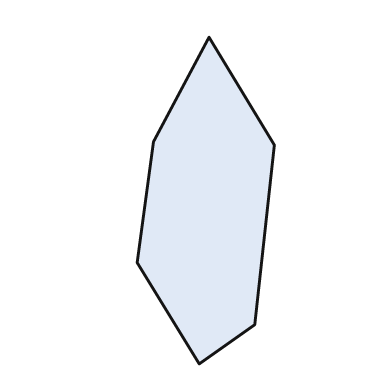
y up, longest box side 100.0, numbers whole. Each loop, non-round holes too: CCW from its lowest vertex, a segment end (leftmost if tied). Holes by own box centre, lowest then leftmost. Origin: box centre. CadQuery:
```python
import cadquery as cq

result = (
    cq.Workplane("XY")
    .moveTo(-2.0, -50.0)
    .lineTo(15.0, -38.0)
    .lineTo(21.0, 17.0)
    .lineTo(1.0, 50.0)
    .lineTo(-16.0, 18.0)
    .lineTo(-21.0, -19.0)
    .close()
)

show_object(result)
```